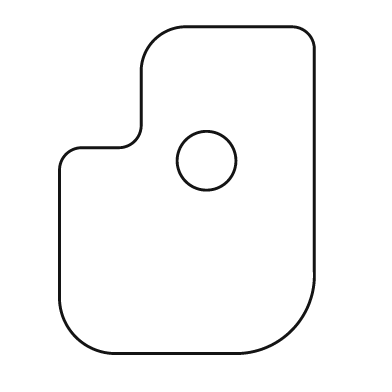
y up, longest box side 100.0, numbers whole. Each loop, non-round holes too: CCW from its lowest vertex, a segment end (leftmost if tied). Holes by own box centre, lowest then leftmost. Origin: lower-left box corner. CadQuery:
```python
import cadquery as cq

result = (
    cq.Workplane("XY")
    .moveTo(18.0, 0.0)
    .lineTo(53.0, 0.0)
    .threePointArc((71.0, 7.0), (78.0, 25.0))
    .lineTo(78.0, 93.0)
    .threePointArc((76.0, 98.0), (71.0, 100.0))
    .lineTo(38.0, 100.0)
    .threePointArc((29.0, 96.0), (25.0, 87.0))
    .lineTo(25.0, 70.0)
    .threePointArc((23.0, 65.0), (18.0, 63.0))
    .lineTo(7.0, 63.0)
    .threePointArc((2.0, 61.0), (0.0, 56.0))
    .lineTo(0.0, 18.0)
    .threePointArc((5.0, 5.0), (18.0, 0.0))
    .close()
    .moveTo(45.0, 59.0)
    .circle(9.0)
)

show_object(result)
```